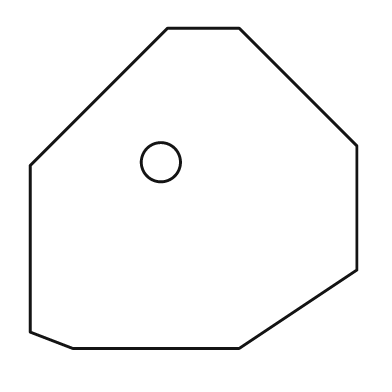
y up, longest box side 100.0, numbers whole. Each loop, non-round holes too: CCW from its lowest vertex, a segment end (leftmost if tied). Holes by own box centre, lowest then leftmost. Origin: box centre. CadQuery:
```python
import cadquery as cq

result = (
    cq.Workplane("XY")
    .moveTo(-37.0, -49.0)
    .lineTo(14.0, -49.0)
    .lineTo(50.0, -25.0)
    .lineTo(50.0, 13.0)
    .lineTo(14.0, 49.0)
    .lineTo(-8.0, 49.0)
    .lineTo(-50.0, 7.0)
    .lineTo(-50.0, -44.0)
    .close()
    .moveTo(-10.0, 8.0)
    .circle(6.0)
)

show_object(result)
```